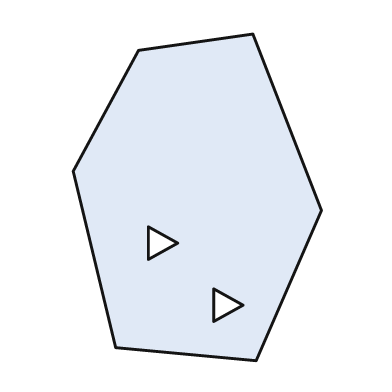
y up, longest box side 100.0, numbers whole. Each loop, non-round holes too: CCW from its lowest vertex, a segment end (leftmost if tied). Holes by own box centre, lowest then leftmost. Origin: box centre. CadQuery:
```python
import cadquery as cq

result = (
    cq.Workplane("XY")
    .moveTo(18.0, -50.0)
    .lineTo(38.0, -4.0)
    .lineTo(17.0, 50.0)
    .lineTo(-18.0, 45.0)
    .lineTo(-38.0, 8.0)
    .lineTo(-25.0, -46.0)
    .close()
    .moveTo(5.0, -38.0)
    .lineTo(14.0, -33.0)
    .lineTo(5.0, -28.0)
    .close()
    .moveTo(-15.0, -19.0)
    .lineTo(-6.0, -14.0)
    .lineTo(-15.0, -9.0)
    .close()
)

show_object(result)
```